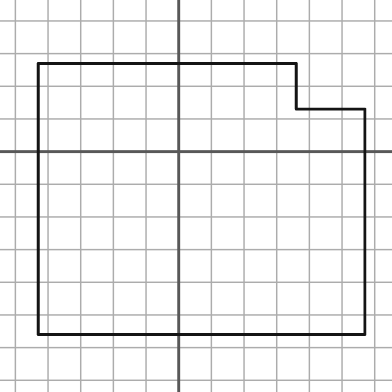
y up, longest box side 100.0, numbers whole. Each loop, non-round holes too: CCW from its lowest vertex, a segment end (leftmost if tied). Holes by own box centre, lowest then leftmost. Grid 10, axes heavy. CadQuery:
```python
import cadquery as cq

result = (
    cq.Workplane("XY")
    .moveTo(-43.0, -56.0)
    .lineTo(57.0, -56.0)
    .lineTo(57.0, 13.0)
    .lineTo(36.0, 13.0)
    .lineTo(36.0, 27.0)
    .lineTo(-43.0, 27.0)
    .close()
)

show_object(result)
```